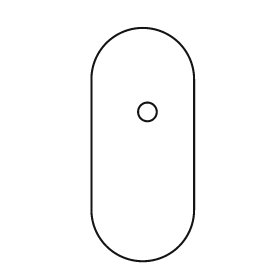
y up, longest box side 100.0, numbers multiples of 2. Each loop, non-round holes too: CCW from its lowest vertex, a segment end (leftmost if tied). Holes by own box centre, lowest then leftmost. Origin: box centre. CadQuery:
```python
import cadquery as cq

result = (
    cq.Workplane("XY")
    .moveTo(-22.0, -28.0)
    .threePointArc((0.0, -50.0), (22.0, -28.0))
    .lineTo(22.0, 28.0)
    .threePointArc((0.0, 50.0), (-22.0, 28.0))
    .close()
    .moveTo(2.0, 14.0)
    .circle(4.0)
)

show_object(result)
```